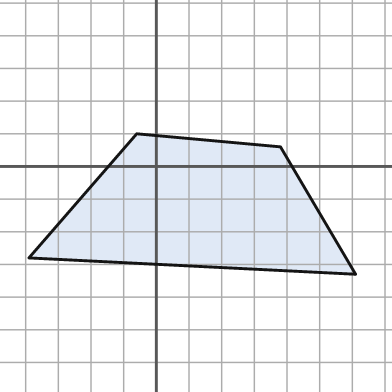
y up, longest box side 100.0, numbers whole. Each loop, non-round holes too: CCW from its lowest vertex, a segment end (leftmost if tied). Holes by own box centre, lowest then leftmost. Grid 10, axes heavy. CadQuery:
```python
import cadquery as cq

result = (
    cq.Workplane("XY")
    .moveTo(61.0, -33.0)
    .lineTo(38.0, 6.0)
    .lineTo(-6.0, 10.0)
    .lineTo(-39.0, -28.0)
    .close()
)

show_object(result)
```